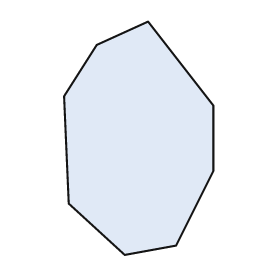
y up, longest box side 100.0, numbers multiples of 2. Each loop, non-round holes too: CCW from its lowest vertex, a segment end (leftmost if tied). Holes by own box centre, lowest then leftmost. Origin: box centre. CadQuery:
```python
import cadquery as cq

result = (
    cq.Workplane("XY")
    .moveTo(-6.0, -50.0)
    .lineTo(16.0, -46.0)
    .lineTo(32.0, -14.0)
    .lineTo(32.0, 14.0)
    .lineTo(4.0, 50.0)
    .lineTo(-18.0, 40.0)
    .lineTo(-32.0, 18.0)
    .lineTo(-30.0, -28.0)
    .close()
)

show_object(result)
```